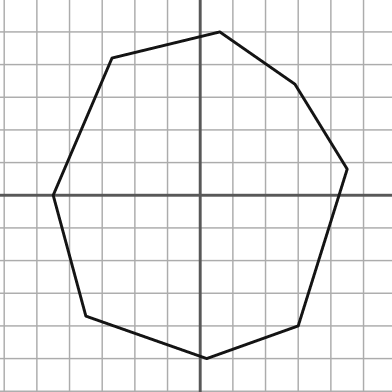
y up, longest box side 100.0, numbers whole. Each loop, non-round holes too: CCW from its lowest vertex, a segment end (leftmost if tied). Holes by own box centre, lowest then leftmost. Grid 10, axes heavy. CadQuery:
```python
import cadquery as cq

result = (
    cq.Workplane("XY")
    .moveTo(2.0, -50.0)
    .lineTo(30.0, -40.0)
    .lineTo(45.0, 8.0)
    .lineTo(29.0, 34.0)
    .lineTo(6.0, 50.0)
    .lineTo(-27.0, 42.0)
    .lineTo(-45.0, 0.0)
    .lineTo(-35.0, -37.0)
    .close()
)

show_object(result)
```